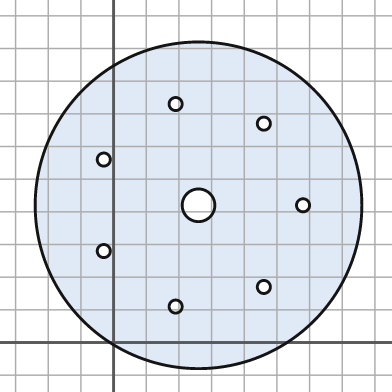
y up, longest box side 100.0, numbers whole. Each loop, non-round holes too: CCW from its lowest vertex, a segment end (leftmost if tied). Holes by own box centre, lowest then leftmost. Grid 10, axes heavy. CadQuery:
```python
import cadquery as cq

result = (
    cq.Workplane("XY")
    .moveTo(26.0, 42.0)
    .circle(50.0)
    .moveTo(19.0, 11.0)
    .circle(2.0)
    .moveTo(46.0, 17.0)
    .circle(2.0)
    .moveTo(-3.0, 28.0)
    .circle(2.0)
    .moveTo(26.0, 42.0)
    .circle(5.0)
    .moveTo(58.0, 42.0)
    .circle(2.0)
    .moveTo(-3.0, 56.0)
    .circle(2.0)
    .moveTo(46.0, 67.0)
    .circle(2.0)
    .moveTo(19.0, 73.0)
    .circle(2.0)
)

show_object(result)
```